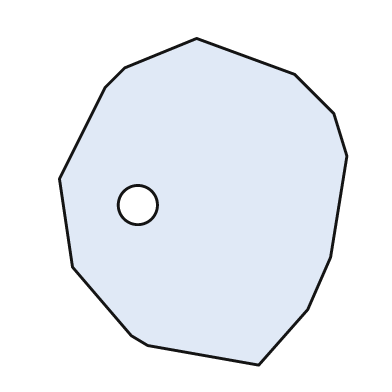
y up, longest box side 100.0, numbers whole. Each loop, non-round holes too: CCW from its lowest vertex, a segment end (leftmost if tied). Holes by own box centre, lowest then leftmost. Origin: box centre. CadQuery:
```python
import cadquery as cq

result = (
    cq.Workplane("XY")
    .moveTo(17.0, -50.0)
    .lineTo(32.0, -33.0)
    .lineTo(39.0, -17.0)
    .lineTo(44.0, 14.0)
    .lineTo(40.0, 27.0)
    .lineTo(28.0, 39.0)
    .lineTo(-2.0, 50.0)
    .lineTo(-24.0, 41.0)
    .lineTo(-30.0, 35.0)
    .lineTo(-44.0, 7.0)
    .lineTo(-40.0, -20.0)
    .lineTo(-22.0, -41.0)
    .lineTo(-17.0, -44.0)
    .close()
    .moveTo(-20.0, -1.0)
    .circle(6.0)
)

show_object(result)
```